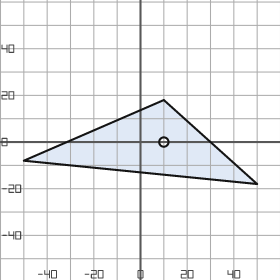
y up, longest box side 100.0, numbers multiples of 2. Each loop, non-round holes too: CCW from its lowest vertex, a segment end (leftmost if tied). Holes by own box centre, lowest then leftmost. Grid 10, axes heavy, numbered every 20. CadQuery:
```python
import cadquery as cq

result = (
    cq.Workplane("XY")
    .moveTo(50.0, -18.0)
    .lineTo(10.0, 18.0)
    .lineTo(-50.0, -8.0)
    .close()
    .moveTo(10.0, 0.0)
    .circle(2.0)
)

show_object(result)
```